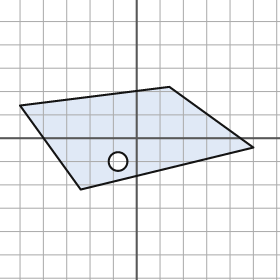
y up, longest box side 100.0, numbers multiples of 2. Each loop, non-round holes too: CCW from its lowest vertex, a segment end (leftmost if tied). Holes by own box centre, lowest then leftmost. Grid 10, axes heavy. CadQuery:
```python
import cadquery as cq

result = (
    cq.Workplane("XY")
    .moveTo(-24.0, -22.0)
    .lineTo(50.0, -4.0)
    .lineTo(14.0, 22.0)
    .lineTo(-50.0, 14.0)
    .close()
    .moveTo(-8.0, -10.0)
    .circle(4.0)
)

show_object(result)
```